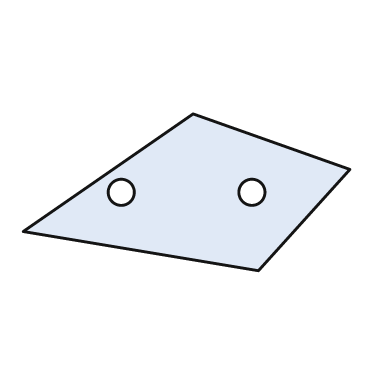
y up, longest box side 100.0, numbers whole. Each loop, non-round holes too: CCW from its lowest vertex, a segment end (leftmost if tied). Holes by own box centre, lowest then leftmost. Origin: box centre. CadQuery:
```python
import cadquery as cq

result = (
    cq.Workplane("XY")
    .moveTo(22.0, -24.0)
    .lineTo(50.0, 7.0)
    .lineTo(2.0, 24.0)
    .lineTo(-50.0, -12.0)
    .close()
    .moveTo(-20.0, 0.0)
    .circle(4.0)
    .moveTo(20.0, 0.0)
    .circle(4.0)
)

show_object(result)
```